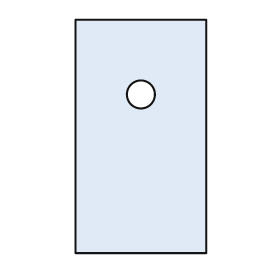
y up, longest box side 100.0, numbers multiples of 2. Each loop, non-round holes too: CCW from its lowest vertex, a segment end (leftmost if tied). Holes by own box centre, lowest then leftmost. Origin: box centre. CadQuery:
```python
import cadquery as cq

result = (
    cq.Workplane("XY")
    .moveTo(-28.0, -50.0)
    .lineTo(28.0, -50.0)
    .lineTo(28.0, 50.0)
    .lineTo(-28.0, 50.0)
    .close()
    .moveTo(0.0, 18.0)
    .circle(6.0)
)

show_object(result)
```